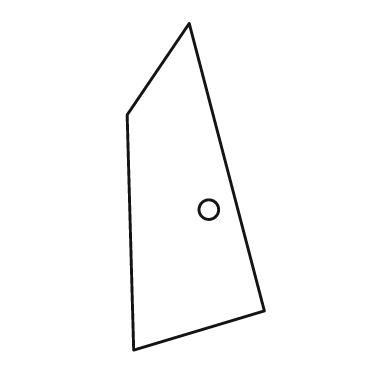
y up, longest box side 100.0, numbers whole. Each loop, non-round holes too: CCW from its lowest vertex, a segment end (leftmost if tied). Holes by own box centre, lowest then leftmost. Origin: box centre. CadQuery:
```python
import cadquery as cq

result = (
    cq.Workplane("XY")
    .moveTo(-19.0, -50.0)
    .lineTo(21.0, -38.0)
    .lineTo(-2.0, 50.0)
    .lineTo(-21.0, 22.0)
    .close()
    .moveTo(4.0, -7.0)
    .circle(3.0)
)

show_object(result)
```